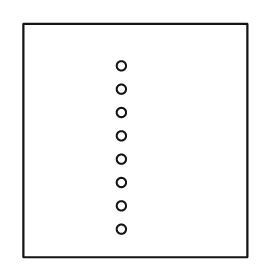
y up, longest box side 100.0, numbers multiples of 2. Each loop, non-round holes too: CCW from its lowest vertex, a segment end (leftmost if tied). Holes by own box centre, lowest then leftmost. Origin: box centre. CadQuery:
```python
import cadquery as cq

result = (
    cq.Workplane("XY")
    .moveTo(-48.0, -50.0)
    .lineTo(48.0, -50.0)
    .lineTo(48.0, 50.0)
    .lineTo(-48.0, 50.0)
    .close()
    .moveTo(-6.0, -38.0)
    .circle(2.0)
    .moveTo(-6.0, -28.0)
    .circle(2.0)
    .moveTo(-6.0, -18.0)
    .circle(2.0)
    .moveTo(-6.0, -8.0)
    .circle(2.0)
    .moveTo(-6.0, 2.0)
    .circle(2.0)
    .moveTo(-6.0, 12.0)
    .circle(2.0)
    .moveTo(-6.0, 22.0)
    .circle(2.0)
    .moveTo(-6.0, 32.0)
    .circle(2.0)
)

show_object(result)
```